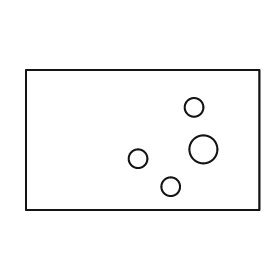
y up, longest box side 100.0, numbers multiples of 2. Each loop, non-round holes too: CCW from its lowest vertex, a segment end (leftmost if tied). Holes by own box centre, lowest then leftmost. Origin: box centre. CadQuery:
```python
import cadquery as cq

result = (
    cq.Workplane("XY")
    .moveTo(-50.0, -30.0)
    .lineTo(50.0, -30.0)
    .lineTo(50.0, 30.0)
    .lineTo(-50.0, 30.0)
    .close()
    .moveTo(12.0, -20.0)
    .circle(4.0)
    .moveTo(-2.0, -8.0)
    .circle(4.0)
    .moveTo(26.0, -4.0)
    .circle(6.0)
    .moveTo(22.0, 14.0)
    .circle(4.0)
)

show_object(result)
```